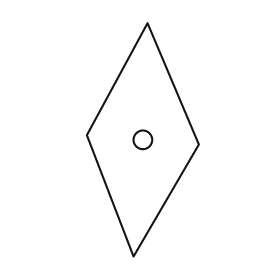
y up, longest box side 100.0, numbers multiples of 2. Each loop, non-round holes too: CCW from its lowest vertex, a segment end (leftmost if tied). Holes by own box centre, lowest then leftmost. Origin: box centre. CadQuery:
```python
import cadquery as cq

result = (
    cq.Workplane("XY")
    .moveTo(-4.0, -50.0)
    .lineTo(24.0, -2.0)
    .lineTo(2.0, 50.0)
    .lineTo(-24.0, 2.0)
    .close()
    .moveTo(0.0, 0.0)
    .circle(4.0)
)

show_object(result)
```